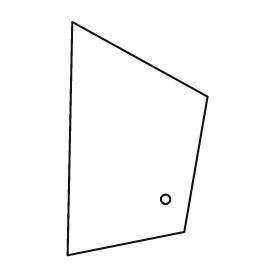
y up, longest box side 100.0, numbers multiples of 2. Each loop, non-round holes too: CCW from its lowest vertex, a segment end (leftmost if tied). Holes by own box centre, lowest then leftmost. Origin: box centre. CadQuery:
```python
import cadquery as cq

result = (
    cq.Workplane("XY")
    .moveTo(-30.0, -50.0)
    .lineTo(20.0, -40.0)
    .lineTo(30.0, 18.0)
    .lineTo(-28.0, 50.0)
    .close()
    .moveTo(12.0, -26.0)
    .circle(2.0)
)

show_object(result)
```